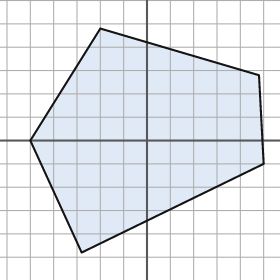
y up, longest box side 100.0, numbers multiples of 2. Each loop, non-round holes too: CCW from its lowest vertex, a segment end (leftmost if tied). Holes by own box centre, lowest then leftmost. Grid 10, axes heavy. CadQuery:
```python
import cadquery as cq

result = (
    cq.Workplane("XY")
    .moveTo(-28.0, -48.0)
    .lineTo(50.0, -10.0)
    .lineTo(48.0, 28.0)
    .lineTo(-20.0, 48.0)
    .lineTo(-50.0, 0.0)
    .close()
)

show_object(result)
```